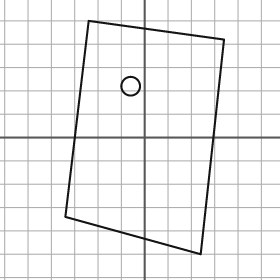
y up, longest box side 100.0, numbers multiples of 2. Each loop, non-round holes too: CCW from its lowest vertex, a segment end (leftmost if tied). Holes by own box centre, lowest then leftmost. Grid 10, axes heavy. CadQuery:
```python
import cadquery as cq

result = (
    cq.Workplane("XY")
    .moveTo(24.0, -50.0)
    .lineTo(34.0, 42.0)
    .lineTo(-24.0, 50.0)
    .lineTo(-34.0, -34.0)
    .close()
    .moveTo(-6.0, 22.0)
    .circle(4.0)
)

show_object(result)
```